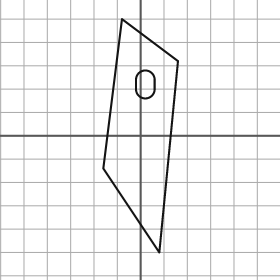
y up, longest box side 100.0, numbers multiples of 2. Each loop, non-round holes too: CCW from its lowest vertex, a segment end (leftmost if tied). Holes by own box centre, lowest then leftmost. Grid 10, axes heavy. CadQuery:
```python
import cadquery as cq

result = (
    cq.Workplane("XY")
    .moveTo(8.0, -50.0)
    .lineTo(16.0, 32.0)
    .lineTo(-8.0, 50.0)
    .lineTo(-16.0, -14.0)
    .close()
    .moveTo(-2.0, 20.0)
    .threePointArc((2.0, 16.0), (6.0, 20.0))
    .lineTo(6.0, 24.0)
    .threePointArc((2.0, 28.0), (-2.0, 24.0))
    .close()
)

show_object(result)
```